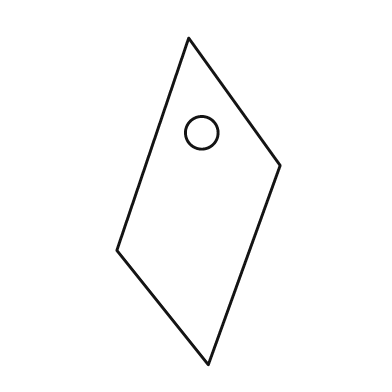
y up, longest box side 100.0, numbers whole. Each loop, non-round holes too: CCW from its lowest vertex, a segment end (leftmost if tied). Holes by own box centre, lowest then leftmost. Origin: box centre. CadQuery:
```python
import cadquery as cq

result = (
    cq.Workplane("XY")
    .moveTo(3.0, -50.0)
    .lineTo(25.0, 11.0)
    .lineTo(-3.0, 50.0)
    .lineTo(-25.0, -15.0)
    .close()
    .moveTo(1.0, 21.0)
    .circle(5.0)
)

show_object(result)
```